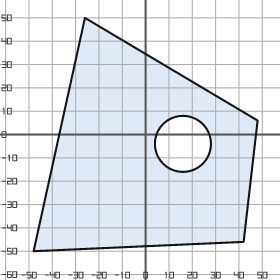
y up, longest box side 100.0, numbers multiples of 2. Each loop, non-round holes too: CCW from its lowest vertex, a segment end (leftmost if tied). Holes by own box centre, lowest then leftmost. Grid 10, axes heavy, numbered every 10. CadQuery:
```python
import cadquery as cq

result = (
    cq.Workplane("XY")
    .moveTo(-48.0, -50.0)
    .lineTo(42.0, -46.0)
    .lineTo(48.0, 6.0)
    .lineTo(-26.0, 50.0)
    .close()
    .moveTo(16.0, -4.0)
    .circle(12.0)
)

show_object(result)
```